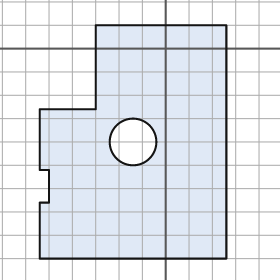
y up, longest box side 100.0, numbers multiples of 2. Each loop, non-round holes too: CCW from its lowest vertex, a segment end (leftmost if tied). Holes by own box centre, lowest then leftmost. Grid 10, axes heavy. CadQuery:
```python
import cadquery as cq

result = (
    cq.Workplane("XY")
    .moveTo(-54.0, -90.0)
    .lineTo(26.0, -90.0)
    .lineTo(26.0, 10.0)
    .lineTo(-30.0, 10.0)
    .lineTo(-30.0, -26.0)
    .lineTo(-54.0, -26.0)
    .lineTo(-54.0, -52.0)
    .lineTo(-50.0, -52.0)
    .lineTo(-50.0, -66.0)
    .lineTo(-54.0, -66.0)
    .close()
    .moveTo(-14.0, -40.0)
    .circle(10.0)
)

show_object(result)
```